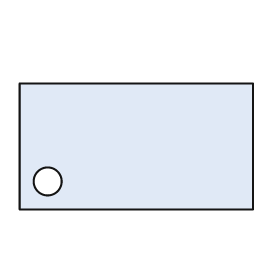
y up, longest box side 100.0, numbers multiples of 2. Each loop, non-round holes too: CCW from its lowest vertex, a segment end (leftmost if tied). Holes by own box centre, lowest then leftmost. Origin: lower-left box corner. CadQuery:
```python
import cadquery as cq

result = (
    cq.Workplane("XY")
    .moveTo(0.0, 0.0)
    .lineTo(100.0, 0.0)
    .lineTo(100.0, 54.0)
    .lineTo(0.0, 54.0)
    .close()
    .moveTo(12.0, 12.0)
    .circle(6.0)
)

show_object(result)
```